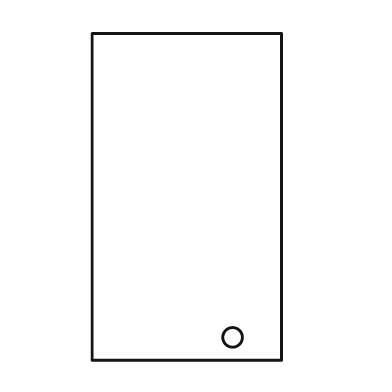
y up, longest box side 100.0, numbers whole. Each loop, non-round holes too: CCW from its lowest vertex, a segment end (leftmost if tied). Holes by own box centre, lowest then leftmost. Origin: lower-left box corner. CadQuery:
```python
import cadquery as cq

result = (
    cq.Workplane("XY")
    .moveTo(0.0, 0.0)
    .lineTo(58.0, 0.0)
    .lineTo(58.0, 100.0)
    .lineTo(0.0, 100.0)
    .close()
    .moveTo(43.0, 7.0)
    .circle(3.0)
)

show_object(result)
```